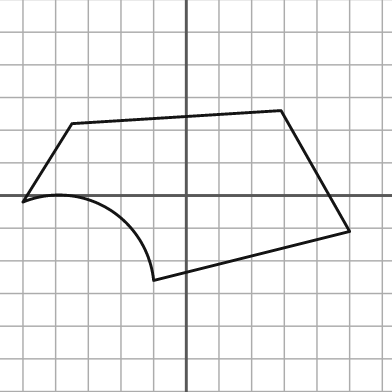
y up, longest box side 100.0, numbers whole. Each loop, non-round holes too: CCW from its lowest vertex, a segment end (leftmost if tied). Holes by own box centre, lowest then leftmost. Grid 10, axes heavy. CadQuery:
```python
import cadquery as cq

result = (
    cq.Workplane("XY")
    .moveTo(-10.0, -26.0)
    .lineTo(50.0, -11.0)
    .lineTo(29.0, 26.0)
    .lineTo(-35.0, 22.0)
    .lineTo(-50.0, -2.0)
    .threePointArc((-24.0, -4.0), (-10.0, -26.0))
    .close()
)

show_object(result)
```